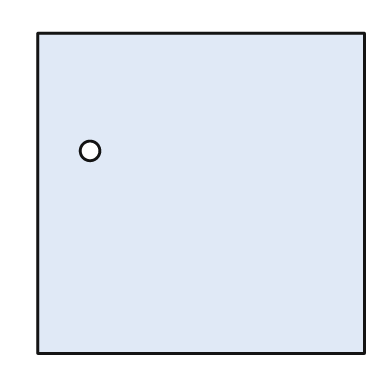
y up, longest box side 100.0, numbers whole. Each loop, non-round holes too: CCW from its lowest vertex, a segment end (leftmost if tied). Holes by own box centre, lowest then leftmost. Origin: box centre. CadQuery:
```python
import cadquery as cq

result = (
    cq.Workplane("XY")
    .moveTo(-50.0, -49.0)
    .lineTo(50.0, -49.0)
    .lineTo(50.0, 49.0)
    .lineTo(-50.0, 49.0)
    .close()
    .moveTo(-34.0, 13.0)
    .circle(3.0)
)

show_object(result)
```